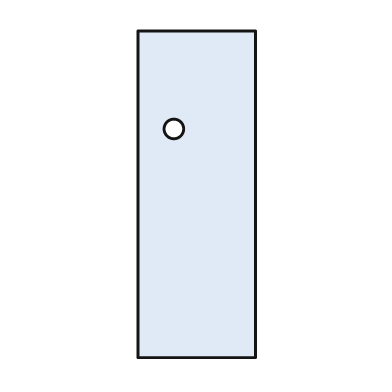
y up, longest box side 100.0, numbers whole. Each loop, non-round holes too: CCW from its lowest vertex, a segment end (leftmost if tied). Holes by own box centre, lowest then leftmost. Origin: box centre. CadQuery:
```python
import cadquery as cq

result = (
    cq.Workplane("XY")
    .moveTo(-18.0, -50.0)
    .lineTo(18.0, -50.0)
    .lineTo(18.0, 50.0)
    .lineTo(-18.0, 50.0)
    .close()
    .moveTo(-7.0, 20.0)
    .circle(3.0)
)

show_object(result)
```